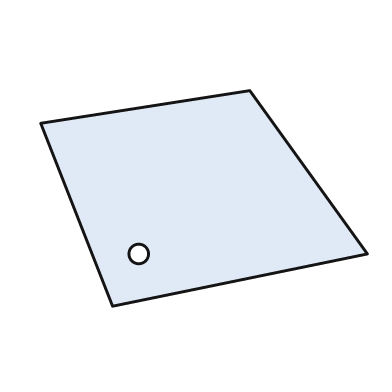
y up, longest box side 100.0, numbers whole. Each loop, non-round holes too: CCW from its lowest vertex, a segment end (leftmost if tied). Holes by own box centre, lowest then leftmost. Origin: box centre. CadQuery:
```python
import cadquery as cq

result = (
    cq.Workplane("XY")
    .moveTo(-28.0, -33.0)
    .lineTo(50.0, -17.0)
    .lineTo(14.0, 33.0)
    .lineTo(-50.0, 23.0)
    .close()
    .moveTo(-20.0, -17.0)
    .circle(3.0)
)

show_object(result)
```